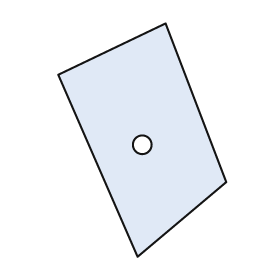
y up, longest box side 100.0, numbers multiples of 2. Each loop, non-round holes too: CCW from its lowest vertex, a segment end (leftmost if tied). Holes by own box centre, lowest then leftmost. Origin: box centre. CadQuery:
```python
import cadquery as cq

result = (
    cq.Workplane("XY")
    .moveTo(-2.0, -50.0)
    .lineTo(36.0, -18.0)
    .lineTo(10.0, 50.0)
    .lineTo(-36.0, 28.0)
    .close()
    .moveTo(0.0, -2.0)
    .circle(4.0)
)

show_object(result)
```